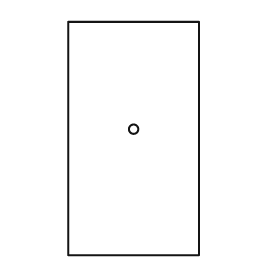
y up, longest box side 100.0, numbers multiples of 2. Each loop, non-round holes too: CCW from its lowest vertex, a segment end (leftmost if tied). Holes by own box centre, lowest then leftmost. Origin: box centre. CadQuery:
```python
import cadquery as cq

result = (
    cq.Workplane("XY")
    .moveTo(-28.0, -50.0)
    .lineTo(28.0, -50.0)
    .lineTo(28.0, 50.0)
    .lineTo(-28.0, 50.0)
    .close()
    .moveTo(0.0, 4.0)
    .circle(2.0)
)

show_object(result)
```